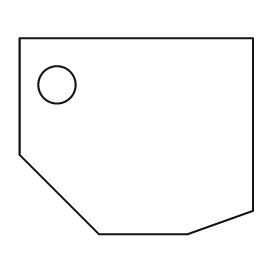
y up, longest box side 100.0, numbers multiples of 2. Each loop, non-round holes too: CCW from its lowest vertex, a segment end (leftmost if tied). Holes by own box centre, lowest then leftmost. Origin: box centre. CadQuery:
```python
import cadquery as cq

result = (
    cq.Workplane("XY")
    .moveTo(-16.0, -42.0)
    .lineTo(22.0, -42.0)
    .lineTo(50.0, -32.0)
    .lineTo(50.0, 42.0)
    .lineTo(-50.0, 42.0)
    .lineTo(-50.0, -8.0)
    .close()
    .moveTo(-34.0, 22.0)
    .circle(8.0)
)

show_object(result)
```